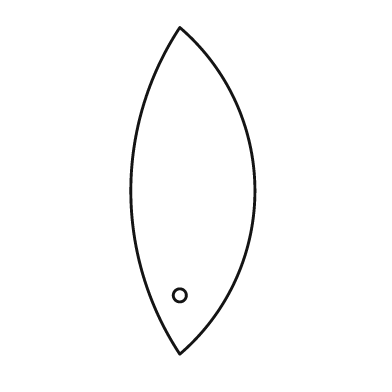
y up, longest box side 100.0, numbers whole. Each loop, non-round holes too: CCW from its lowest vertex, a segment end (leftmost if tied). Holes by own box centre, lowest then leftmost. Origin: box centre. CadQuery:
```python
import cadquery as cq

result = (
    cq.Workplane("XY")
    .moveTo(-4.0, -50.0)
    .threePointArc((19.0, 0.0), (-4.0, 50.0))
    .threePointArc((-19.0, 0.0), (-4.0, -50.0))
    .close()
    .moveTo(-4.0, -32.0)
    .circle(2.0)
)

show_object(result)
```